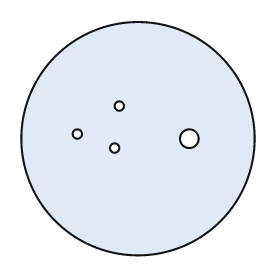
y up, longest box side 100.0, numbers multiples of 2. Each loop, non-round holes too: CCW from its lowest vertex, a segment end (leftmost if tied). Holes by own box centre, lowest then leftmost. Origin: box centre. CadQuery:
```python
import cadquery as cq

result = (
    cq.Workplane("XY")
    .moveTo(0.0, 0.0)
    .circle(50.0)
    .moveTo(-10.0, -4.0)
    .circle(2.0)
    .moveTo(22.0, 0.0)
    .circle(4.0)
    .moveTo(-26.0, 2.0)
    .circle(2.0)
    .moveTo(-8.0, 14.0)
    .circle(2.0)
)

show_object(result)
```